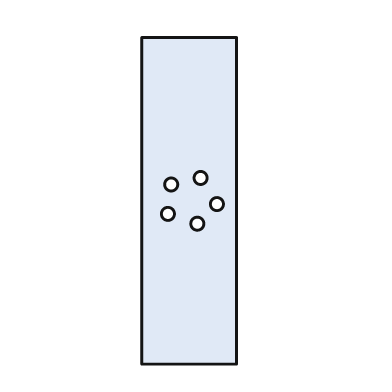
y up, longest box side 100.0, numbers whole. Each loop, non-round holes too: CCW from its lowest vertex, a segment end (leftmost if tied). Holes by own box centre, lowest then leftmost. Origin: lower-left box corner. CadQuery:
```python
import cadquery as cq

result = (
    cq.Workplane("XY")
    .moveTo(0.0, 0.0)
    .lineTo(29.0, 0.0)
    .lineTo(29.0, 100.0)
    .lineTo(0.0, 100.0)
    .close()
    .moveTo(17.0, 43.0)
    .circle(2.0)
    .moveTo(8.0, 46.0)
    .circle(2.0)
    .moveTo(23.0, 49.0)
    .circle(2.0)
    .moveTo(9.0, 55.0)
    .circle(2.0)
    .moveTo(18.0, 57.0)
    .circle(2.0)
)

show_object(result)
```